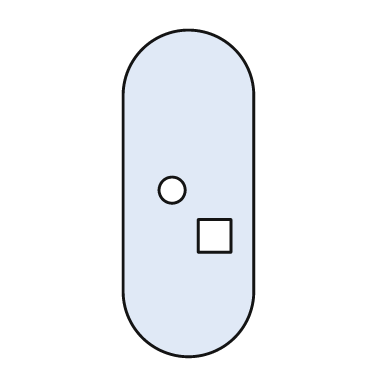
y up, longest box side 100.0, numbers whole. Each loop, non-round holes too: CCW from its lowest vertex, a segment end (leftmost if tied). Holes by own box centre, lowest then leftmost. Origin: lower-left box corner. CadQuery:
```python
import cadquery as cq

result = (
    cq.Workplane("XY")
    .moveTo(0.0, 20.0)
    .threePointArc((20.0, 0.0), (40.0, 20.0))
    .lineTo(40.0, 80.0)
    .threePointArc((20.0, 100.0), (0.0, 80.0))
    .close()
    .moveTo(23.0, 32.0)
    .lineTo(33.0, 32.0)
    .lineTo(33.0, 42.0)
    .lineTo(23.0, 42.0)
    .close()
    .moveTo(15.0, 51.0)
    .circle(4.0)
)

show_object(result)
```